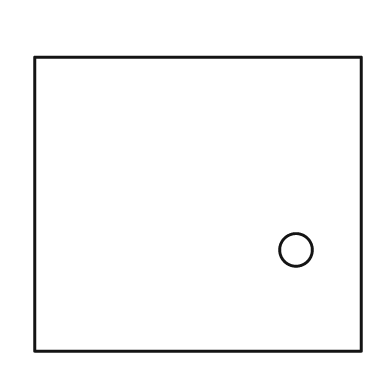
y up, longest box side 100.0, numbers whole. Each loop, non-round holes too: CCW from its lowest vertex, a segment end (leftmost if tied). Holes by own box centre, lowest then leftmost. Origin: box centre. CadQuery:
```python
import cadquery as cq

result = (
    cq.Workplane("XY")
    .moveTo(-50.0, -45.0)
    .lineTo(50.0, -45.0)
    .lineTo(50.0, 45.0)
    .lineTo(-50.0, 45.0)
    .close()
    .moveTo(30.0, -14.0)
    .circle(5.0)
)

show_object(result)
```